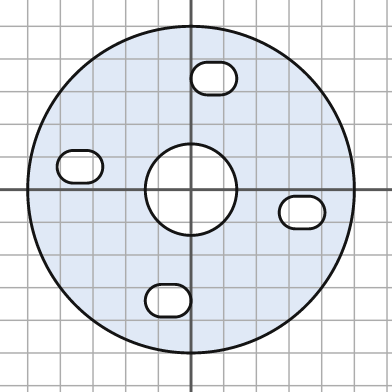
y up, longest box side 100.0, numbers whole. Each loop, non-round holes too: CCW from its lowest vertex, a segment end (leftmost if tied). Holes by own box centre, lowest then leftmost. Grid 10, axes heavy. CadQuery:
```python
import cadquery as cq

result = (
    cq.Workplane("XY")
    .moveTo(0.0, 0.0)
    .circle(50.0)
    .moveTo(-9.0, -39.0)
    .lineTo(-5.0, -39.0)
    .threePointArc((0.0, -34.0), (-5.0, -29.0))
    .lineTo(-9.0, -29.0)
    .threePointArc((-14.0, -34.0), (-9.0, -39.0))
    .close()
    .moveTo(32.0, -12.0)
    .lineTo(36.0, -12.0)
    .threePointArc((41.0, -7.0), (36.0, -2.0))
    .lineTo(32.0, -2.0)
    .threePointArc((27.0, -7.0), (32.0, -12.0))
    .close()
    .moveTo(0.0, 0.0)
    .circle(14.0)
    .moveTo(-36.0, 2.0)
    .lineTo(-32.0, 2.0)
    .threePointArc((-27.0, 7.0), (-32.0, 12.0))
    .lineTo(-36.0, 12.0)
    .threePointArc((-41.0, 7.0), (-36.0, 2.0))
    .close()
    .moveTo(5.0, 29.0)
    .lineTo(9.0, 29.0)
    .threePointArc((14.0, 34.0), (9.0, 39.0))
    .lineTo(5.0, 39.0)
    .threePointArc((0.0, 34.0), (5.0, 29.0))
    .close()
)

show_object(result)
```